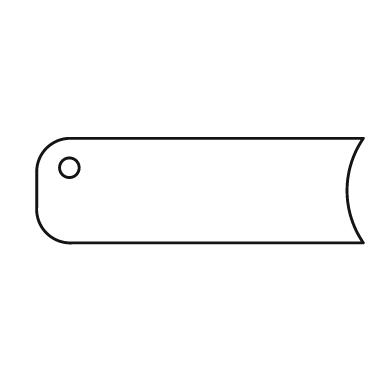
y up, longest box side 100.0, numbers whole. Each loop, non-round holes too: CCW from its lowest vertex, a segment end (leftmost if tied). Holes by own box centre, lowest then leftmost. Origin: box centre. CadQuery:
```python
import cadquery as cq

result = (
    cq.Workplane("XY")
    .moveTo(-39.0, -16.0)
    .lineTo(50.0, -16.0)
    .threePointArc((45.0, 0.0), (50.0, 16.0))
    .lineTo(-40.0, 16.0)
    .threePointArc((-47.0, 13.0), (-50.0, 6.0))
    .lineTo(-50.0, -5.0)
    .threePointArc((-47.0, -13.0), (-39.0, -16.0))
    .close()
    .moveTo(-40.0, 7.0)
    .circle(3.0)
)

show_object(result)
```